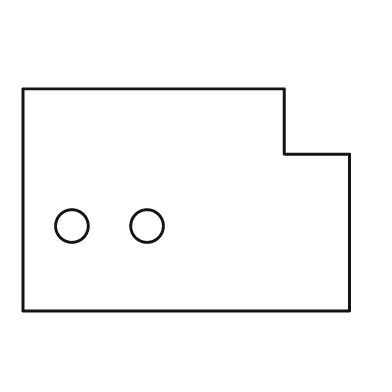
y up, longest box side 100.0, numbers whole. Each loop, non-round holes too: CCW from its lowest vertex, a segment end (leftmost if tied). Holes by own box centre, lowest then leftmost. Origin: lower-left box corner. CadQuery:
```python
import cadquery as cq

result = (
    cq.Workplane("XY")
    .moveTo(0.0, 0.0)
    .lineTo(100.0, 0.0)
    .lineTo(100.0, 48.0)
    .lineTo(80.0, 48.0)
    .lineTo(80.0, 68.0)
    .lineTo(0.0, 68.0)
    .close()
    .moveTo(15.0, 26.0)
    .circle(5.0)
    .moveTo(38.0, 26.0)
    .circle(5.0)
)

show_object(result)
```